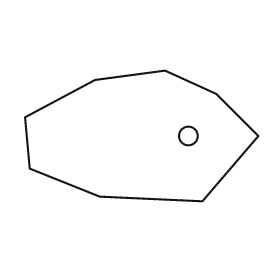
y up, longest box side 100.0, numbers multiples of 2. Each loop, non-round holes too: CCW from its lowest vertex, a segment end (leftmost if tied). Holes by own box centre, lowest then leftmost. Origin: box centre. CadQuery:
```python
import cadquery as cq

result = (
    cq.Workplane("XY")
    .moveTo(26.0, -28.0)
    .lineTo(50.0, 0.0)
    .lineTo(32.0, 18.0)
    .lineTo(10.0, 28.0)
    .lineTo(-20.0, 24.0)
    .lineTo(-50.0, 8.0)
    .lineTo(-48.0, -14.0)
    .lineTo(-18.0, -26.0)
    .close()
    .moveTo(20.0, 0.0)
    .circle(4.0)
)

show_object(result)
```